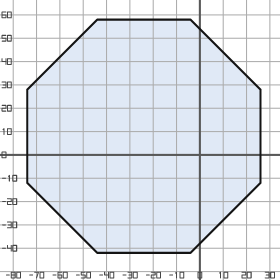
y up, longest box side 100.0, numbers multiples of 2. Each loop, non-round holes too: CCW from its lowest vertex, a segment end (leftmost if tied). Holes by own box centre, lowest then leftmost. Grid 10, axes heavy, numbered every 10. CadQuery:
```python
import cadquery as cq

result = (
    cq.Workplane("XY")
    .moveTo(-44.0, -42.0)
    .lineTo(-4.0, -42.0)
    .lineTo(26.0, -12.0)
    .lineTo(26.0, 28.0)
    .lineTo(-4.0, 58.0)
    .lineTo(-44.0, 58.0)
    .lineTo(-74.0, 28.0)
    .lineTo(-74.0, -12.0)
    .close()
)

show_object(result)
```